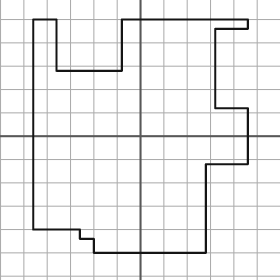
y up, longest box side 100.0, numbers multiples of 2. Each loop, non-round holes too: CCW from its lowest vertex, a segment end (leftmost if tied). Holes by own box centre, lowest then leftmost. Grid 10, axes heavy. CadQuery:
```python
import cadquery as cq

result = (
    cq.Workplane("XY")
    .moveTo(-20.0, -50.0)
    .lineTo(28.0, -50.0)
    .lineTo(28.0, -12.0)
    .lineTo(46.0, -12.0)
    .lineTo(46.0, 12.0)
    .lineTo(32.0, 12.0)
    .lineTo(32.0, 46.0)
    .lineTo(46.0, 46.0)
    .lineTo(46.0, 50.0)
    .lineTo(-8.0, 50.0)
    .lineTo(-8.0, 28.0)
    .lineTo(-36.0, 28.0)
    .lineTo(-36.0, 50.0)
    .lineTo(-46.0, 50.0)
    .lineTo(-46.0, -40.0)
    .lineTo(-26.0, -40.0)
    .lineTo(-26.0, -44.0)
    .lineTo(-20.0, -44.0)
    .close()
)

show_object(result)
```